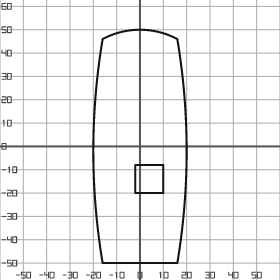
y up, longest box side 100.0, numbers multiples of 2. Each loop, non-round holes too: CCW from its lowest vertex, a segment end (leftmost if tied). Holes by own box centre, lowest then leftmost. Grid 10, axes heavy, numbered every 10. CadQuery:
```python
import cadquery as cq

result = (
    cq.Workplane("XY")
    .moveTo(-16.0, -50.0)
    .lineTo(16.0, -50.0)
    .threePointArc((20.0, -2.0), (16.0, 46.0))
    .threePointArc((0.0, 50.0), (-16.0, 46.0))
    .threePointArc((-20.0, -2.0), (-16.0, -50.0))
    .close()
    .moveTo(-2.0, -20.0)
    .lineTo(10.0, -20.0)
    .lineTo(10.0, -8.0)
    .lineTo(-2.0, -8.0)
    .close()
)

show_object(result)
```